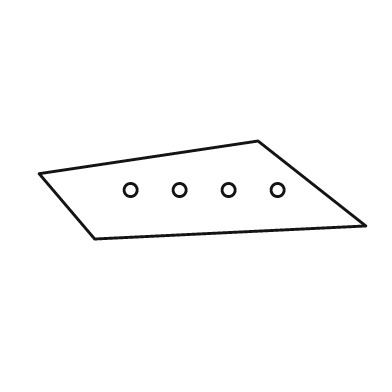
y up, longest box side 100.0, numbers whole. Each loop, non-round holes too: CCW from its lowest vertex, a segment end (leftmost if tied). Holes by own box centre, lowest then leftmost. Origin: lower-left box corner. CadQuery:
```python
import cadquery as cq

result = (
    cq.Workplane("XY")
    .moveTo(17.0, 0.0)
    .lineTo(100.0, 4.0)
    .lineTo(67.0, 30.0)
    .lineTo(0.0, 20.0)
    .close()
    .moveTo(28.0, 15.0)
    .circle(2.0)
    .moveTo(43.0, 15.0)
    .circle(2.0)
    .moveTo(58.0, 15.0)
    .circle(2.0)
    .moveTo(73.0, 15.0)
    .circle(2.0)
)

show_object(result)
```